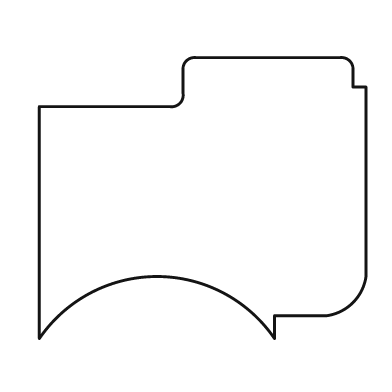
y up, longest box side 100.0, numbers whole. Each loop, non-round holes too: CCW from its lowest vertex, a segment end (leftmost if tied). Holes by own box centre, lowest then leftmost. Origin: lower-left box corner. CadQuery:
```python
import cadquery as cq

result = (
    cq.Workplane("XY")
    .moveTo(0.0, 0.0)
    .threePointArc((36.0, 19.0), (72.0, 0.0))
    .lineTo(72.0, 7.0)
    .lineTo(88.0, 7.0)
    .threePointArc((96.0, 11.0), (100.0, 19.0))
    .lineTo(100.0, 77.0)
    .lineTo(96.0, 77.0)
    .lineTo(96.0, 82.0)
    .threePointArc((95.0, 85.0), (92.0, 86.0))
    .lineTo(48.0, 86.0)
    .threePointArc((45.0, 85.0), (44.0, 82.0))
    .lineTo(44.0, 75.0)
    .threePointArc((43.0, 72.0), (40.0, 71.0))
    .lineTo(0.0, 71.0)
    .close()
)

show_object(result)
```